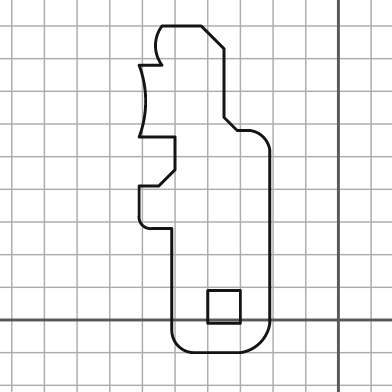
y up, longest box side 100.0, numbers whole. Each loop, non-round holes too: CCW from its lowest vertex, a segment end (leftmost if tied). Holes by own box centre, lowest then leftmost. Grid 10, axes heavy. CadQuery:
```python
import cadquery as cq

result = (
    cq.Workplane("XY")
    .moveTo(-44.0, -10.0)
    .lineTo(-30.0, -10.0)
    .threePointArc((-24.0, -7.0), (-21.0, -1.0))
    .lineTo(-21.0, 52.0)
    .threePointArc((-23.0, 56.0), (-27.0, 58.0))
    .lineTo(-31.0, 58.0)
    .lineTo(-35.0, 62.0)
    .lineTo(-35.0, 83.0)
    .lineTo(-42.0, 90.0)
    .lineTo(-54.0, 90.0)
    .threePointArc((-56.0, 84.0), (-54.0, 78.0))
    .lineTo(-61.0, 78.0)
    .threePointArc((-59.0, 67.0), (-61.0, 56.0))
    .lineTo(-50.0, 56.0)
    .lineTo(-50.0, 46.0)
    .lineTo(-55.0, 41.0)
    .lineTo(-61.0, 41.0)
    .lineTo(-61.0, 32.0)
    .threePointArc((-60.0, 29.0), (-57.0, 28.0))
    .lineTo(-51.0, 28.0)
    .lineTo(-51.0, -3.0)
    .threePointArc((-49.0, -8.0), (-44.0, -10.0))
    .close()
    .moveTo(-40.0, -1.0)
    .lineTo(-30.0, -1.0)
    .lineTo(-30.0, 9.0)
    .lineTo(-40.0, 9.0)
    .close()
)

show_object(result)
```